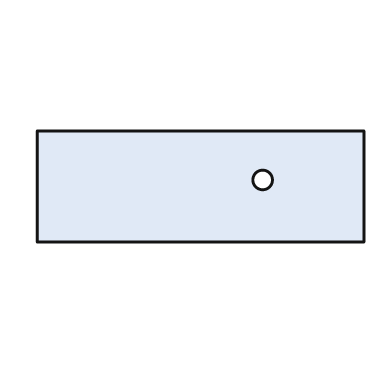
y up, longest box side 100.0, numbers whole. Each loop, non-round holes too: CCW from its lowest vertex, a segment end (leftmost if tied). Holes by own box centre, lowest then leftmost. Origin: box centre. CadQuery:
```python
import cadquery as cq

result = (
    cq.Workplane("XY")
    .moveTo(-50.0, -17.0)
    .lineTo(50.0, -17.0)
    .lineTo(50.0, 17.0)
    .lineTo(-50.0, 17.0)
    .close()
    .moveTo(19.0, 2.0)
    .circle(3.0)
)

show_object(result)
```